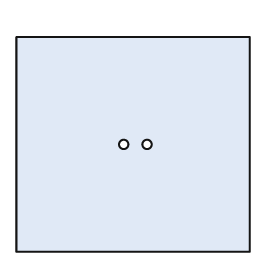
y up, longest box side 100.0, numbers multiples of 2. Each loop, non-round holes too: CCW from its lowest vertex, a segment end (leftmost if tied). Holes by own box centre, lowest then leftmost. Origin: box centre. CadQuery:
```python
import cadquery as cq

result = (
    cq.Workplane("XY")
    .moveTo(-50.0, -46.0)
    .lineTo(50.0, -46.0)
    .lineTo(50.0, 46.0)
    .lineTo(-50.0, 46.0)
    .close()
    .moveTo(-4.0, 0.0)
    .circle(2.0)
    .moveTo(6.0, 0.0)
    .circle(2.0)
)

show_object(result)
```